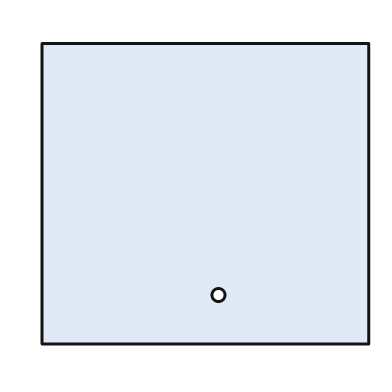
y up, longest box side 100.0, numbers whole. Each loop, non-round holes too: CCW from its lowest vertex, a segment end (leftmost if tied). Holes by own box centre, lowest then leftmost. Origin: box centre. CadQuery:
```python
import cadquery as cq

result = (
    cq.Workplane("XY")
    .moveTo(-50.0, -46.0)
    .lineTo(50.0, -46.0)
    .lineTo(50.0, 46.0)
    .lineTo(-50.0, 46.0)
    .close()
    .moveTo(4.0, -31.0)
    .circle(2.0)
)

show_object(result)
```